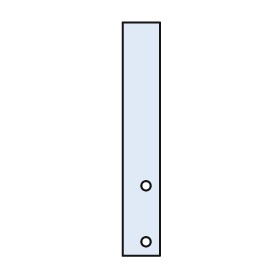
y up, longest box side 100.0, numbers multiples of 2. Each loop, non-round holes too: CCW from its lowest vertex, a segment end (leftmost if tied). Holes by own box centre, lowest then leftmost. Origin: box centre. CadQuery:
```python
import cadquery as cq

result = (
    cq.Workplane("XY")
    .moveTo(-8.0, -50.0)
    .lineTo(8.0, -50.0)
    .lineTo(8.0, 50.0)
    .lineTo(-8.0, 50.0)
    .close()
    .moveTo(2.0, -44.0)
    .circle(2.0)
    .moveTo(2.0, -20.0)
    .circle(2.0)
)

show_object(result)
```